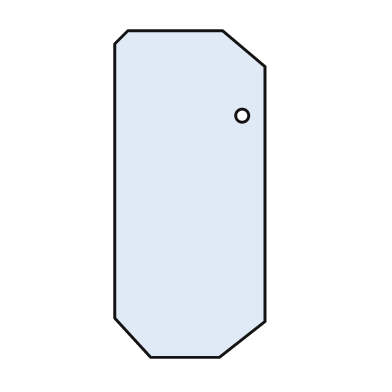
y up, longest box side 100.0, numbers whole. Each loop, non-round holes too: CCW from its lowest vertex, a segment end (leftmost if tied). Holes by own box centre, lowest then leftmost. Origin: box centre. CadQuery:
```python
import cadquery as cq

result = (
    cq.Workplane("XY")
    .moveTo(-12.0, -50.0)
    .lineTo(9.0, -50.0)
    .lineTo(23.0, -39.0)
    .lineTo(23.0, 39.0)
    .lineTo(10.0, 50.0)
    .lineTo(-19.0, 50.0)
    .lineTo(-23.0, 46.0)
    .lineTo(-23.0, -38.0)
    .close()
    .moveTo(16.0, 24.0)
    .circle(2.0)
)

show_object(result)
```